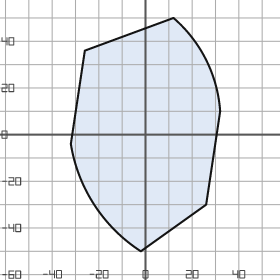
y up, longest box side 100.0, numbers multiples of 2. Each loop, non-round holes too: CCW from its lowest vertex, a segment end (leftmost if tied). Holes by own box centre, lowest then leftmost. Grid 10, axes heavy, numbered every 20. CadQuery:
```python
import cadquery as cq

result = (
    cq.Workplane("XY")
    .moveTo(-2.0, -50.0)
    .lineTo(26.0, -30.0)
    .lineTo(32.0, 10.0)
    .threePointArc((26.0, 32.0), (12.0, 50.0))
    .lineTo(-26.0, 36.0)
    .lineTo(-32.0, -4.0)
    .threePointArc((-22.0, -30.0), (-2.0, -50.0))
    .close()
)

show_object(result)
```